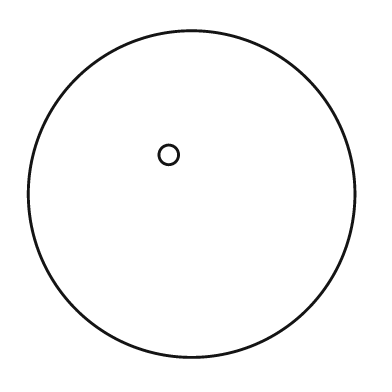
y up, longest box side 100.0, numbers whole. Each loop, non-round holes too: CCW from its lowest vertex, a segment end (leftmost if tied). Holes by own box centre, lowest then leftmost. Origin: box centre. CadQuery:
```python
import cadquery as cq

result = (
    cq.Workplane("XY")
    .moveTo(0.0, 0.0)
    .circle(50.0)
    .moveTo(-7.0, 12.0)
    .circle(3.0)
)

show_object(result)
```